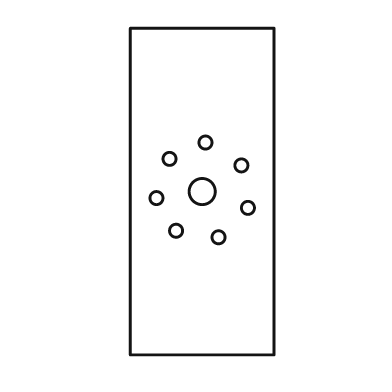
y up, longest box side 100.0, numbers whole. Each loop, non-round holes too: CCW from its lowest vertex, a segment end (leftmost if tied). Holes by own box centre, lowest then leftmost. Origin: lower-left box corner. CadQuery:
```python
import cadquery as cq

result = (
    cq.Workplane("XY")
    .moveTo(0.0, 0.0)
    .lineTo(44.0, 0.0)
    .lineTo(44.0, 100.0)
    .lineTo(0.0, 100.0)
    .close()
    .moveTo(27.0, 36.0)
    .circle(2.0)
    .moveTo(14.0, 38.0)
    .circle(2.0)
    .moveTo(36.0, 45.0)
    .circle(2.0)
    .moveTo(8.0, 48.0)
    .circle(2.0)
    .moveTo(22.0, 50.0)
    .circle(4.0)
    .moveTo(34.0, 58.0)
    .circle(2.0)
    .moveTo(12.0, 60.0)
    .circle(2.0)
    .moveTo(23.0, 65.0)
    .circle(2.0)
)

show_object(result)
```